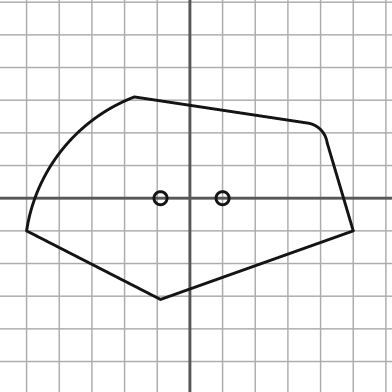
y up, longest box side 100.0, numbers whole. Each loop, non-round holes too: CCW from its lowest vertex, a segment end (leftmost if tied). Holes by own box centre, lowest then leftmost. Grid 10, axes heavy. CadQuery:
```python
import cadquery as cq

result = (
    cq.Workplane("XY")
    .moveTo(-9.0, -31.0)
    .lineTo(50.0, -10.0)
    .lineTo(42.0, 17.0)
    .threePointArc((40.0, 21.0), (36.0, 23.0))
    .lineTo(-17.0, 31.0)
    .threePointArc((-39.0, 15.0), (-50.0, -10.0))
    .close()
    .moveTo(-9.0, 0.0)
    .circle(2.0)
    .moveTo(10.0, 0.0)
    .circle(2.0)
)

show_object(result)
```